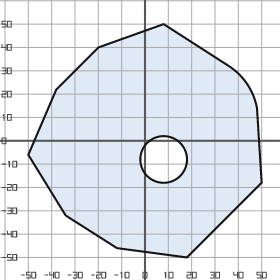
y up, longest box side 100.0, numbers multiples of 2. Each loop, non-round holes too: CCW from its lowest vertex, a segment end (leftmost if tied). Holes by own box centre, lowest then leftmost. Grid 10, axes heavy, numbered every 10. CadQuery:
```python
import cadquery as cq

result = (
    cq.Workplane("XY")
    .moveTo(18.0, -50.0)
    .lineTo(50.0, -18.0)
    .lineTo(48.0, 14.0)
    .threePointArc((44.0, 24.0), (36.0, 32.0))
    .lineTo(8.0, 50.0)
    .lineTo(-20.0, 40.0)
    .lineTo(-38.0, 22.0)
    .lineTo(-50.0, -6.0)
    .lineTo(-34.0, -32.0)
    .lineTo(-12.0, -46.0)
    .close()
    .moveTo(8.0, -8.0)
    .circle(10.0)
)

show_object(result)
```